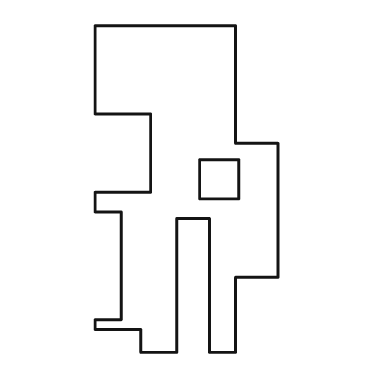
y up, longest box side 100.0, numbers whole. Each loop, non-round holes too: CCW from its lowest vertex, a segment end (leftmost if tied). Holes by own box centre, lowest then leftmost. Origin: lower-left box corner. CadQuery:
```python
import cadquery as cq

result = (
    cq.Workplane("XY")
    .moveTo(14.0, 0.0)
    .lineTo(25.0, 0.0)
    .lineTo(25.0, 41.0)
    .lineTo(35.0, 41.0)
    .lineTo(35.0, 0.0)
    .lineTo(43.0, 0.0)
    .lineTo(43.0, 23.0)
    .lineTo(56.0, 23.0)
    .lineTo(56.0, 64.0)
    .lineTo(43.0, 64.0)
    .lineTo(43.0, 100.0)
    .lineTo(0.0, 100.0)
    .lineTo(0.0, 73.0)
    .lineTo(17.0, 73.0)
    .lineTo(17.0, 49.0)
    .lineTo(0.0, 49.0)
    .lineTo(0.0, 43.0)
    .lineTo(8.0, 43.0)
    .lineTo(8.0, 10.0)
    .lineTo(0.0, 10.0)
    .lineTo(0.0, 7.0)
    .lineTo(14.0, 7.0)
    .close()
    .moveTo(32.0, 47.0)
    .lineTo(44.0, 47.0)
    .lineTo(44.0, 59.0)
    .lineTo(32.0, 59.0)
    .close()
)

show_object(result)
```